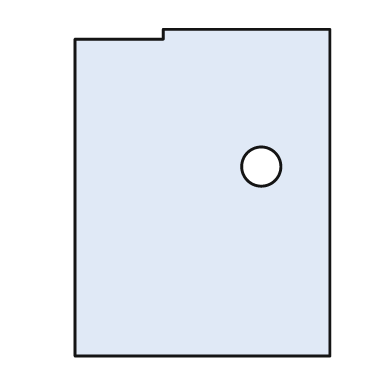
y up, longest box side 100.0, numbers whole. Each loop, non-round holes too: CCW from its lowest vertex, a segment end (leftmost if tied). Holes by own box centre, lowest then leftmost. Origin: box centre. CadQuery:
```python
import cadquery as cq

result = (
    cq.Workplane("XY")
    .moveTo(-39.0, -50.0)
    .lineTo(39.0, -50.0)
    .lineTo(39.0, 50.0)
    .lineTo(-12.0, 50.0)
    .lineTo(-12.0, 47.0)
    .lineTo(-39.0, 47.0)
    .close()
    .moveTo(18.0, 8.0)
    .circle(6.0)
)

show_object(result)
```